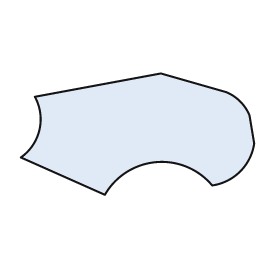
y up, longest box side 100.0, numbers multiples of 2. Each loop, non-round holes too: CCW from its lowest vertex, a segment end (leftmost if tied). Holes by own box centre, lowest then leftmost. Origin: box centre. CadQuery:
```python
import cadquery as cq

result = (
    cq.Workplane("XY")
    .moveTo(-14.0, -26.0)
    .threePointArc((8.0, -12.0), (32.0, -22.0))
    .threePointArc((44.0, -16.0), (50.0, -4.0))
    .lineTo(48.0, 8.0)
    .threePointArc((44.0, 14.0), (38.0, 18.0))
    .lineTo(10.0, 26.0)
    .lineTo(-44.0, 16.0)
    .threePointArc((-42.0, 2.0), (-50.0, -10.0))
    .close()
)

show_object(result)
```